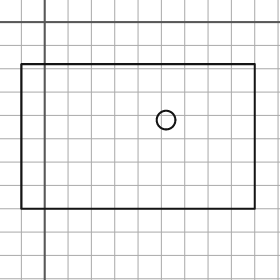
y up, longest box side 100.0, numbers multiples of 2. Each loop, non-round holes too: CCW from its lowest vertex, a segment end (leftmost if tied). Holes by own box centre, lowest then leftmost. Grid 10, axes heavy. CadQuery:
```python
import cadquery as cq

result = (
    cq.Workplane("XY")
    .moveTo(-10.0, -80.0)
    .lineTo(90.0, -80.0)
    .lineTo(90.0, -18.0)
    .lineTo(-10.0, -18.0)
    .close()
    .moveTo(52.0, -42.0)
    .circle(4.0)
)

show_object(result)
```